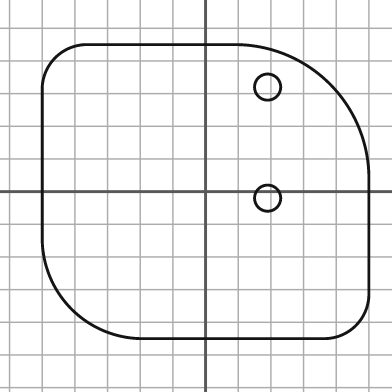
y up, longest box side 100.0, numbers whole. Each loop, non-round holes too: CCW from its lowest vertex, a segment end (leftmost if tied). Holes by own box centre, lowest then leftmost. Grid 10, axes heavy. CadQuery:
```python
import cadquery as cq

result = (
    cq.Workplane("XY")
    .moveTo(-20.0, -45.0)
    .lineTo(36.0, -45.0)
    .threePointArc((46.0, -41.0), (50.0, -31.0))
    .lineTo(50.0, 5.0)
    .threePointArc((38.0, 33.0), (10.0, 45.0))
    .lineTo(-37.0, 45.0)
    .threePointArc((-46.0, 41.0), (-50.0, 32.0))
    .lineTo(-50.0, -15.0)
    .threePointArc((-41.0, -36.0), (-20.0, -45.0))
    .close()
    .moveTo(19.0, -2.0)
    .circle(4.0)
    .moveTo(19.0, 32.0)
    .circle(4.0)
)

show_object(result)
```